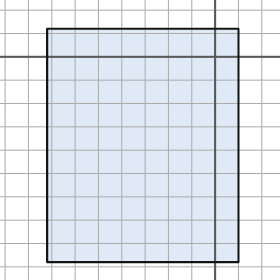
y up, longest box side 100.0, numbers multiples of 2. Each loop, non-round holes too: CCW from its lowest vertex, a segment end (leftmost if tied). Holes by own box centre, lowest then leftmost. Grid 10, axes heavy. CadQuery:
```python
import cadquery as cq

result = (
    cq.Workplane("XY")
    .moveTo(-72.0, -88.0)
    .lineTo(10.0, -88.0)
    .lineTo(10.0, 12.0)
    .lineTo(-72.0, 12.0)
    .close()
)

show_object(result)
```